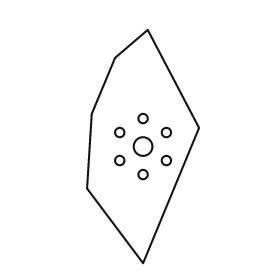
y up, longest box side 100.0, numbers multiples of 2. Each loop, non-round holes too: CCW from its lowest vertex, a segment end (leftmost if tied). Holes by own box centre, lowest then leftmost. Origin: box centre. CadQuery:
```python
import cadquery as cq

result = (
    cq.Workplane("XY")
    .moveTo(0.0, -50.0)
    .lineTo(24.0, 8.0)
    .lineTo(2.0, 50.0)
    .lineTo(-12.0, 38.0)
    .lineTo(-22.0, 14.0)
    .lineTo(-24.0, -18.0)
    .close()
    .moveTo(0.0, -12.0)
    .circle(2.0)
    .moveTo(-10.0, -6.0)
    .circle(2.0)
    .moveTo(10.0, -6.0)
    .circle(2.0)
    .moveTo(0.0, 0.0)
    .circle(4.0)
    .moveTo(-10.0, 6.0)
    .circle(2.0)
    .moveTo(10.0, 6.0)
    .circle(2.0)
    .moveTo(0.0, 12.0)
    .circle(2.0)
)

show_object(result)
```